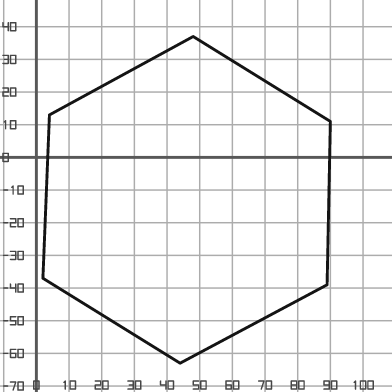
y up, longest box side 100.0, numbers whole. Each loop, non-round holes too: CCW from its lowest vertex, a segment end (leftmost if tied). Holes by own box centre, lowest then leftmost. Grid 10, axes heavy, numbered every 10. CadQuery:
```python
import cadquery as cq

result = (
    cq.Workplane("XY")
    .moveTo(44.0, -63.0)
    .lineTo(89.0, -39.0)
    .lineTo(90.0, 11.0)
    .lineTo(48.0, 37.0)
    .lineTo(4.0, 13.0)
    .lineTo(2.0, -37.0)
    .close()
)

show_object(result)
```